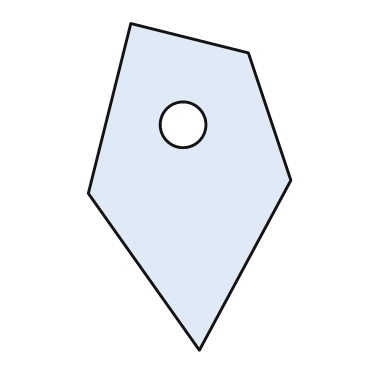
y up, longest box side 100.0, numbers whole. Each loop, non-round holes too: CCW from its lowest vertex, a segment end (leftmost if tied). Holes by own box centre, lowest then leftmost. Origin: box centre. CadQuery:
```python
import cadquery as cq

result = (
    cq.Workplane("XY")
    .moveTo(3.0, -50.0)
    .lineTo(31.0, 2.0)
    .lineTo(18.0, 41.0)
    .lineTo(-18.0, 50.0)
    .lineTo(-31.0, -2.0)
    .close()
    .moveTo(-2.0, 19.0)
    .circle(7.0)
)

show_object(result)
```